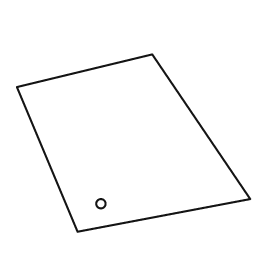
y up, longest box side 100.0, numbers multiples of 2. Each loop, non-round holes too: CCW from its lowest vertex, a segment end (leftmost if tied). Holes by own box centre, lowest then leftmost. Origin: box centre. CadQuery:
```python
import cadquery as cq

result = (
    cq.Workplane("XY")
    .moveTo(-24.0, -38.0)
    .lineTo(50.0, -24.0)
    .lineTo(8.0, 38.0)
    .lineTo(-50.0, 24.0)
    .close()
    .moveTo(-14.0, -26.0)
    .circle(2.0)
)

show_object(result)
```